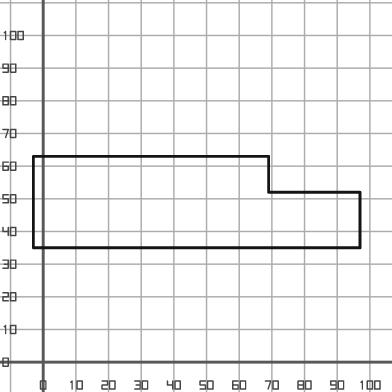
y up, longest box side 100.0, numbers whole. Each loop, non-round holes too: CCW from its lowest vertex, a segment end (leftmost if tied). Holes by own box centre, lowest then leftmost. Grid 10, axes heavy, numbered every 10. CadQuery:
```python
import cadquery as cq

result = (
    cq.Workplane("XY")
    .moveTo(-3.0, 35.0)
    .lineTo(97.0, 35.0)
    .lineTo(97.0, 52.0)
    .lineTo(69.0, 52.0)
    .lineTo(69.0, 63.0)
    .lineTo(-3.0, 63.0)
    .close()
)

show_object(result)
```